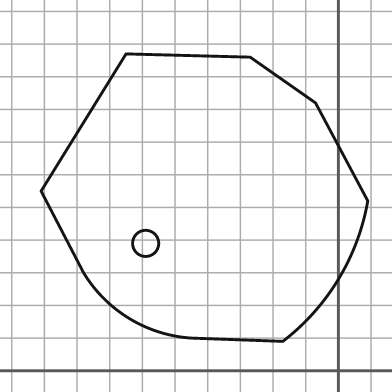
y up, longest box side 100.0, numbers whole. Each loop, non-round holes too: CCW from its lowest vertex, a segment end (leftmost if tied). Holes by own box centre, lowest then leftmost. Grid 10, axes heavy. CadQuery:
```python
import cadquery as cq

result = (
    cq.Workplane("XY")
    .moveTo(-17.0, 9.0)
    .threePointArc((0.0, 28.0), (9.0, 52.0))
    .lineTo(-7.0, 82.0)
    .lineTo(-27.0, 96.0)
    .lineTo(-65.0, 97.0)
    .lineTo(-91.0, 55.0)
    .lineTo(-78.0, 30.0)
    .threePointArc((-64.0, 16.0), (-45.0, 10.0))
    .close()
    .moveTo(-59.0, 39.0)
    .circle(4.0)
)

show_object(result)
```